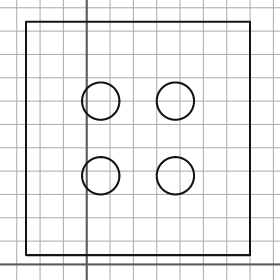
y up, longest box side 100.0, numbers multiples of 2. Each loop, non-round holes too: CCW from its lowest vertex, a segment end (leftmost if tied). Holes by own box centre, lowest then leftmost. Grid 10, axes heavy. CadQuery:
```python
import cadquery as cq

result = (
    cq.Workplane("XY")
    .moveTo(-26.0, 4.0)
    .lineTo(70.0, 4.0)
    .lineTo(70.0, 104.0)
    .lineTo(-26.0, 104.0)
    .close()
    .moveTo(6.0, 38.0)
    .circle(8.0)
    .moveTo(38.0, 38.0)
    .circle(8.0)
    .moveTo(6.0, 70.0)
    .circle(8.0)
    .moveTo(38.0, 70.0)
    .circle(8.0)
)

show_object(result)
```